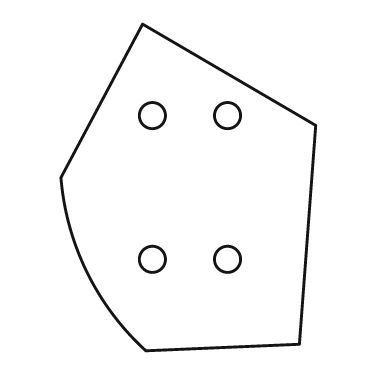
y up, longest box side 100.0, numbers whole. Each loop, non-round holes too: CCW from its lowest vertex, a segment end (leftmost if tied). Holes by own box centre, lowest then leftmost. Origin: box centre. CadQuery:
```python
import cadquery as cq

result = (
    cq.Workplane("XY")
    .moveTo(-13.0, -50.0)
    .lineTo(34.0, -48.0)
    .lineTo(39.0, 19.0)
    .lineTo(-14.0, 50.0)
    .lineTo(-39.0, 3.0)
    .threePointArc((-31.0, -26.0), (-13.0, -50.0))
    .close()
    .moveTo(-11.0, -22.0)
    .circle(4.0)
    .moveTo(12.0, -22.0)
    .circle(4.0)
    .moveTo(-11.0, 22.0)
    .circle(4.0)
    .moveTo(12.0, 22.0)
    .circle(4.0)
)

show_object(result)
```